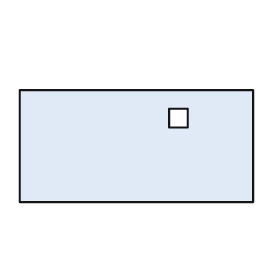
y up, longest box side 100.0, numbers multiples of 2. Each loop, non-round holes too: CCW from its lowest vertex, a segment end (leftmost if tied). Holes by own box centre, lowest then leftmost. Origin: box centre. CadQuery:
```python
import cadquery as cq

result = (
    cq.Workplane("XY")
    .moveTo(-50.0, -24.0)
    .lineTo(50.0, -24.0)
    .lineTo(50.0, 24.0)
    .lineTo(-50.0, 24.0)
    .close()
    .moveTo(14.0, 8.0)
    .lineTo(22.0, 8.0)
    .lineTo(22.0, 16.0)
    .lineTo(14.0, 16.0)
    .close()
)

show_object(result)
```